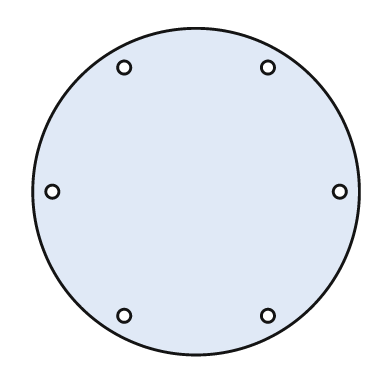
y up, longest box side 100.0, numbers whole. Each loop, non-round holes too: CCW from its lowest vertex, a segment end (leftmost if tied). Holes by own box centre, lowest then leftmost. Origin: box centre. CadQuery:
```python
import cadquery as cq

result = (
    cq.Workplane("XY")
    .moveTo(0.0, 0.0)
    .circle(50.0)
    .moveTo(-22.0, -38.0)
    .circle(2.0)
    .moveTo(22.0, -38.0)
    .circle(2.0)
    .moveTo(-44.0, 0.0)
    .circle(2.0)
    .moveTo(44.0, 0.0)
    .circle(2.0)
    .moveTo(-22.0, 38.0)
    .circle(2.0)
    .moveTo(22.0, 38.0)
    .circle(2.0)
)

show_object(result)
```